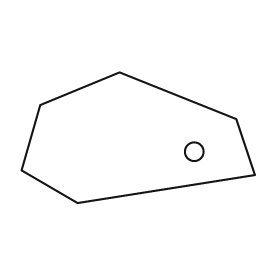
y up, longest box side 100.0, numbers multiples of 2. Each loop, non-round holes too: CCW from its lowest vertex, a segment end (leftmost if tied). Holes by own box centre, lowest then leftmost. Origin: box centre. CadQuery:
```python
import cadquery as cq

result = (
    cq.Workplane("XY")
    .moveTo(-26.0, -28.0)
    .lineTo(50.0, -16.0)
    .lineTo(42.0, 8.0)
    .lineTo(-8.0, 28.0)
    .lineTo(-42.0, 14.0)
    .lineTo(-50.0, -14.0)
    .close()
    .moveTo(24.0, -6.0)
    .circle(4.0)
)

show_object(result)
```